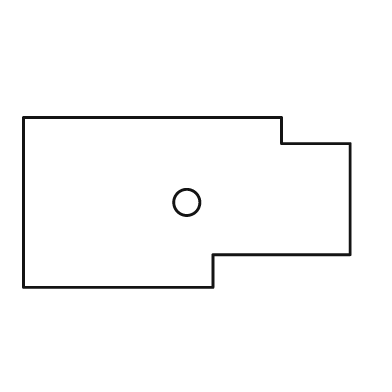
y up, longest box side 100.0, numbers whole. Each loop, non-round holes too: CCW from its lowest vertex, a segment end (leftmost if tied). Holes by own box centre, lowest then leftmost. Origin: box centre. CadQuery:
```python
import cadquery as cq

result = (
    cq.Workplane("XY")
    .moveTo(-50.0, -26.0)
    .lineTo(8.0, -26.0)
    .lineTo(8.0, -16.0)
    .lineTo(50.0, -16.0)
    .lineTo(50.0, 18.0)
    .lineTo(29.0, 18.0)
    .lineTo(29.0, 26.0)
    .lineTo(-50.0, 26.0)
    .close()
    .moveTo(0.0, 0.0)
    .circle(4.0)
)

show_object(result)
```